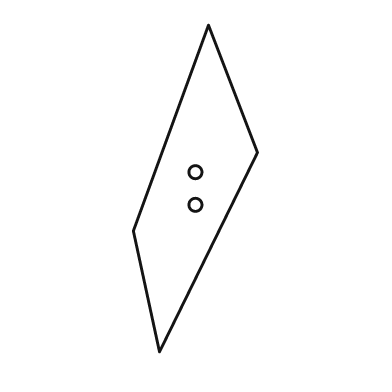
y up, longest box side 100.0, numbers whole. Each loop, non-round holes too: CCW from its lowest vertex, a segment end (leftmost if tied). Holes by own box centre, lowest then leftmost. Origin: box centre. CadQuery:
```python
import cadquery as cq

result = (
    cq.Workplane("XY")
    .moveTo(-11.0, -50.0)
    .lineTo(19.0, 11.0)
    .lineTo(4.0, 50.0)
    .lineTo(-19.0, -13.0)
    .close()
    .moveTo(0.0, -5.0)
    .circle(2.0)
    .moveTo(0.0, 5.0)
    .circle(2.0)
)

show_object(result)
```